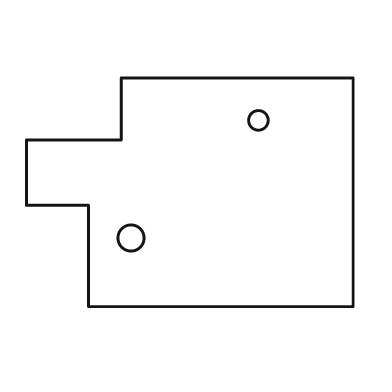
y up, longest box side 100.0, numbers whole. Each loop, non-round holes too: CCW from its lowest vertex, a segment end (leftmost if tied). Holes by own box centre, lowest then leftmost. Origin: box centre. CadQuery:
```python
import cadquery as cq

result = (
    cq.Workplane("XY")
    .moveTo(-31.0, -35.0)
    .lineTo(50.0, -35.0)
    .lineTo(50.0, 35.0)
    .lineTo(-21.0, 35.0)
    .lineTo(-21.0, 16.0)
    .lineTo(-50.0, 16.0)
    .lineTo(-50.0, -4.0)
    .lineTo(-31.0, -4.0)
    .close()
    .moveTo(-18.0, -14.0)
    .circle(4.0)
    .moveTo(21.0, 22.0)
    .circle(3.0)
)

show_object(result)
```